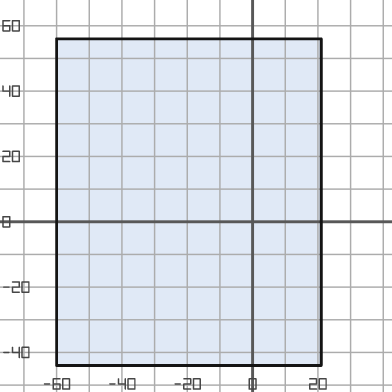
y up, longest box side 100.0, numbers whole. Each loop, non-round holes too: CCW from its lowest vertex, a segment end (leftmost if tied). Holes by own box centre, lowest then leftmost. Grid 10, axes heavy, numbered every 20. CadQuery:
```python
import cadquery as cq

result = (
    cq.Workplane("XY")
    .moveTo(-60.0, -44.0)
    .lineTo(21.0, -44.0)
    .lineTo(21.0, 56.0)
    .lineTo(-60.0, 56.0)
    .close()
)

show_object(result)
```